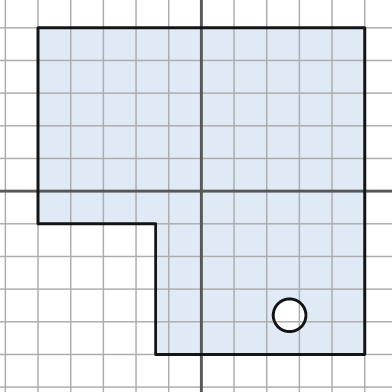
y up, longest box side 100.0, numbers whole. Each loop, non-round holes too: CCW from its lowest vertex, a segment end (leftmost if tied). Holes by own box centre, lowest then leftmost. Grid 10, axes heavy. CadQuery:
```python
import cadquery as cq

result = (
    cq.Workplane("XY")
    .moveTo(-14.0, -50.0)
    .lineTo(50.0, -50.0)
    .lineTo(50.0, 50.0)
    .lineTo(-50.0, 50.0)
    .lineTo(-50.0, -10.0)
    .lineTo(-14.0, -10.0)
    .close()
    .moveTo(27.0, -38.0)
    .circle(5.0)
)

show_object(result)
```